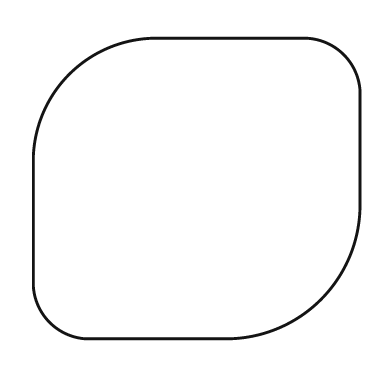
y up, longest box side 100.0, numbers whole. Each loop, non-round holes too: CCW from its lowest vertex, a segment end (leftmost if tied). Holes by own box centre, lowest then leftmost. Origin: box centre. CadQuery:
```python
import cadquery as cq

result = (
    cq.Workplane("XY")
    .moveTo(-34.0, -46.0)
    .lineTo(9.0, -46.0)
    .threePointArc((38.0, -34.0), (50.0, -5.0))
    .lineTo(50.0, 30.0)
    .threePointArc((45.0, 41.0), (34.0, 46.0))
    .lineTo(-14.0, 46.0)
    .threePointArc((-39.0, 35.0), (-50.0, 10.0))
    .lineTo(-50.0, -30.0)
    .threePointArc((-45.0, -41.0), (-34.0, -46.0))
    .close()
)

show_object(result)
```